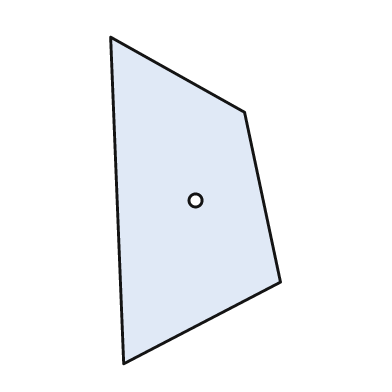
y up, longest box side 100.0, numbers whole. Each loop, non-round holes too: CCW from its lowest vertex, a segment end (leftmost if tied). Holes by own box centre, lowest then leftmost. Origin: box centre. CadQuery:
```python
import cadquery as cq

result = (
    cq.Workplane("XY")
    .moveTo(-22.0, -50.0)
    .lineTo(26.0, -25.0)
    .lineTo(15.0, 27.0)
    .lineTo(-26.0, 50.0)
    .close()
    .moveTo(0.0, 0.0)
    .circle(2.0)
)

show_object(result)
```